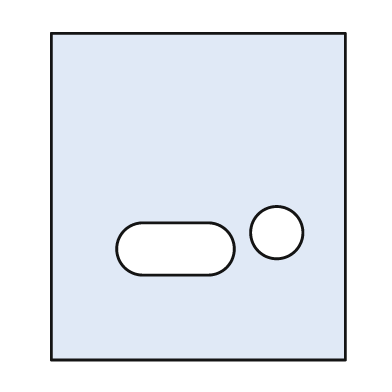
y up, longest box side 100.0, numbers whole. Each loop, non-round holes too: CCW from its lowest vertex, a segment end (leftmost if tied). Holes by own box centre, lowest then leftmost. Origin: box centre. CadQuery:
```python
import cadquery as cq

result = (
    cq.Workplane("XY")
    .moveTo(-45.0, -50.0)
    .lineTo(45.0, -50.0)
    .lineTo(45.0, 50.0)
    .lineTo(-45.0, 50.0)
    .close()
    .moveTo(-17.0, -24.0)
    .lineTo(3.0, -24.0)
    .threePointArc((11.0, -16.0), (3.0, -8.0))
    .lineTo(-17.0, -8.0)
    .threePointArc((-25.0, -16.0), (-17.0, -24.0))
    .close()
    .moveTo(24.0, -11.0)
    .circle(8.0)
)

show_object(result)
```